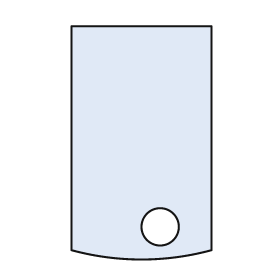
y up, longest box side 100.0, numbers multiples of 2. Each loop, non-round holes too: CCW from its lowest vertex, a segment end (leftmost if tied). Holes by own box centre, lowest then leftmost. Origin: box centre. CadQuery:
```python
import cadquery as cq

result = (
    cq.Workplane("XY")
    .moveTo(-30.0, -46.0)
    .threePointArc((0.0, -50.0), (30.0, -46.0))
    .lineTo(30.0, 50.0)
    .lineTo(-30.0, 50.0)
    .close()
    .moveTo(8.0, -36.0)
    .circle(8.0)
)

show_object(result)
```